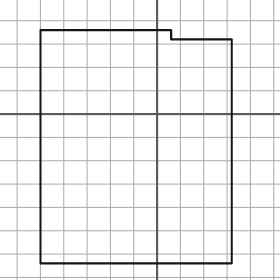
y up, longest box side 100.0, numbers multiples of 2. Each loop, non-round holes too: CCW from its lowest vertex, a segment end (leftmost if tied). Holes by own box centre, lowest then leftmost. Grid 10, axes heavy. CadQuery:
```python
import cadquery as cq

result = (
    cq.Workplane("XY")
    .moveTo(-50.0, -64.0)
    .lineTo(32.0, -64.0)
    .lineTo(32.0, 32.0)
    .lineTo(6.0, 32.0)
    .lineTo(6.0, 36.0)
    .lineTo(-50.0, 36.0)
    .close()
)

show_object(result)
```